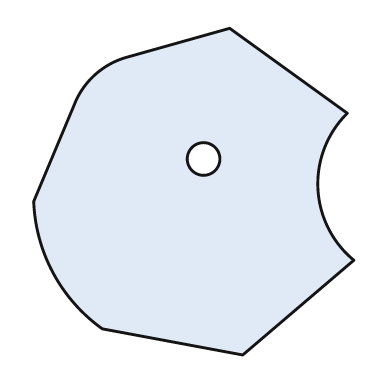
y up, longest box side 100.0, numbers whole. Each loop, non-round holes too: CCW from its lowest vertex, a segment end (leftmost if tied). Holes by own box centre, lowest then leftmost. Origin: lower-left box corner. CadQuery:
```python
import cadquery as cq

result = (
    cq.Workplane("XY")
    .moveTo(64.0, 0.0)
    .lineTo(98.0, 29.0)
    .threePointArc((87.0, 51.0), (96.0, 74.0))
    .lineTo(60.0, 100.0)
    .lineTo(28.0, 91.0)
    .threePointArc((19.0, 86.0), (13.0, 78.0))
    .lineTo(0.0, 47.0)
    .threePointArc((6.0, 25.0), (21.0, 8.0))
    .close()
    .moveTo(52.0, 60.0)
    .circle(5.0)
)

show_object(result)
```